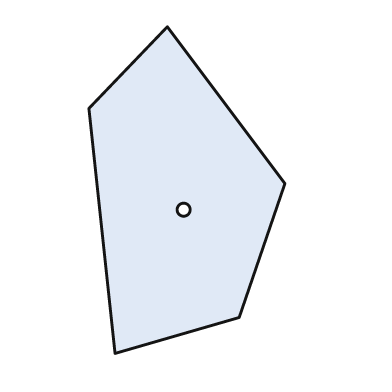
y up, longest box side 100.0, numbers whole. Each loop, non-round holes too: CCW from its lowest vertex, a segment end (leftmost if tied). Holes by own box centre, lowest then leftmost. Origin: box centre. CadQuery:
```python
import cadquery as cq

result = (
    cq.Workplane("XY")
    .moveTo(-22.0, -50.0)
    .lineTo(16.0, -39.0)
    .lineTo(30.0, 2.0)
    .lineTo(-6.0, 50.0)
    .lineTo(-30.0, 25.0)
    .close()
    .moveTo(-1.0, -6.0)
    .circle(2.0)
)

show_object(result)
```